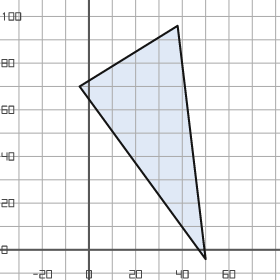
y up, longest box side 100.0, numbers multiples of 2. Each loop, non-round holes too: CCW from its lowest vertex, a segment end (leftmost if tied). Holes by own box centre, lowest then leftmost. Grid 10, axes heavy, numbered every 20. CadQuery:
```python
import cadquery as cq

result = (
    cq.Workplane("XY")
    .moveTo(50.0, -4.0)
    .lineTo(38.0, 96.0)
    .lineTo(-4.0, 70.0)
    .close()
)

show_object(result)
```